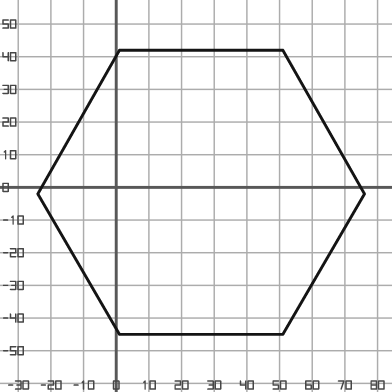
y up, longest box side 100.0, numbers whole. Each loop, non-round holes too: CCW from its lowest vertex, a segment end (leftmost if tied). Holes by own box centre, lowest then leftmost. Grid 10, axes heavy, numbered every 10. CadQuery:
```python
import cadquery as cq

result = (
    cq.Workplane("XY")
    .moveTo(1.0, -45.0)
    .lineTo(51.0, -45.0)
    .lineTo(76.0, -2.0)
    .lineTo(51.0, 42.0)
    .lineTo(1.0, 42.0)
    .lineTo(-24.0, -2.0)
    .close()
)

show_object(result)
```